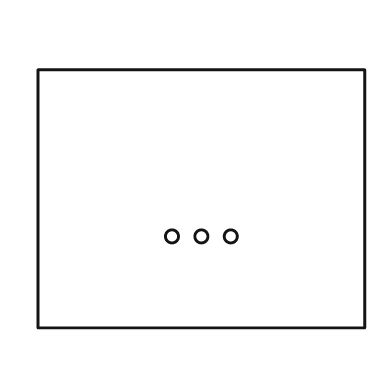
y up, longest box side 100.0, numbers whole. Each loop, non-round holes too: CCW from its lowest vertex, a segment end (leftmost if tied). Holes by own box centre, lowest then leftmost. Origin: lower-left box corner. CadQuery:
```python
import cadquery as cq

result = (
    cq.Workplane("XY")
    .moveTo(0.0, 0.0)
    .lineTo(100.0, 0.0)
    .lineTo(100.0, 79.0)
    .lineTo(0.0, 79.0)
    .close()
    .moveTo(41.0, 28.0)
    .circle(2.0)
    .moveTo(50.0, 28.0)
    .circle(2.0)
    .moveTo(59.0, 28.0)
    .circle(2.0)
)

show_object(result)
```